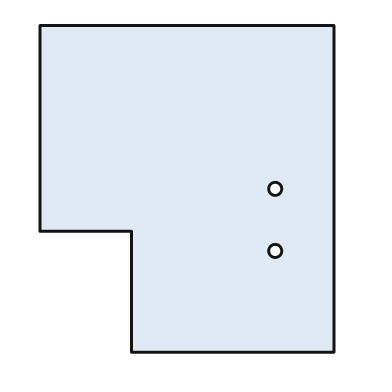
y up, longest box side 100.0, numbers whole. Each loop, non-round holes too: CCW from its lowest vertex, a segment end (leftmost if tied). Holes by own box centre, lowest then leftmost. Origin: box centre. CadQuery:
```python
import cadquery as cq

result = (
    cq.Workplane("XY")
    .moveTo(-17.0, -50.0)
    .lineTo(45.0, -50.0)
    .lineTo(45.0, 50.0)
    .lineTo(-45.0, 50.0)
    .lineTo(-45.0, -13.0)
    .lineTo(-17.0, -13.0)
    .close()
    .moveTo(27.0, -19.0)
    .circle(2.0)
    .moveTo(27.0, 0.0)
    .circle(2.0)
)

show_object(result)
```